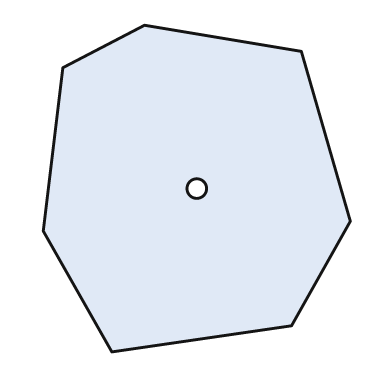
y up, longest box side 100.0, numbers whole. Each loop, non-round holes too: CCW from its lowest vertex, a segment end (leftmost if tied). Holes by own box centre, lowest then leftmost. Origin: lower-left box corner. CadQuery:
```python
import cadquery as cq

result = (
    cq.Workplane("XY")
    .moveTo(21.0, 0.0)
    .lineTo(76.0, 8.0)
    .lineTo(94.0, 40.0)
    .lineTo(79.0, 92.0)
    .lineTo(31.0, 100.0)
    .lineTo(6.0, 87.0)
    .lineTo(0.0, 37.0)
    .close()
    .moveTo(47.0, 50.0)
    .circle(3.0)
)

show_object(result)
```